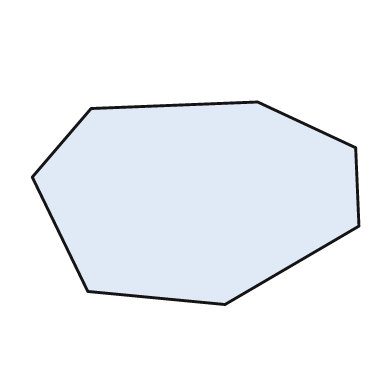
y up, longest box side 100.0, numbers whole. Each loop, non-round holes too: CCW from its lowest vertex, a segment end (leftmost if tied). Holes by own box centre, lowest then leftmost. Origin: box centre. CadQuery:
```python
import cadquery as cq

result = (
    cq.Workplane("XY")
    .moveTo(9.0, -31.0)
    .lineTo(50.0, -7.0)
    .lineTo(49.0, 17.0)
    .lineTo(19.0, 31.0)
    .lineTo(-32.0, 29.0)
    .lineTo(-50.0, 8.0)
    .lineTo(-33.0, -27.0)
    .close()
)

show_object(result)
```